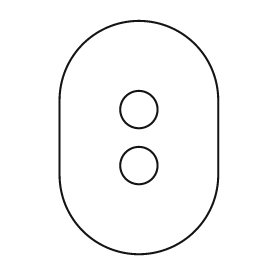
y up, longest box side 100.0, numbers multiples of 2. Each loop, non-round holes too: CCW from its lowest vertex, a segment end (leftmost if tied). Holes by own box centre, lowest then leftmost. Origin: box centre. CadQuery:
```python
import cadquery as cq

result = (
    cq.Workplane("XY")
    .moveTo(-34.0, -16.0)
    .threePointArc((0.0, -50.0), (34.0, -16.0))
    .lineTo(34.0, 16.0)
    .threePointArc((0.0, 50.0), (-34.0, 16.0))
    .close()
    .moveTo(0.0, -12.0)
    .circle(8.0)
    .moveTo(0.0, 12.0)
    .circle(8.0)
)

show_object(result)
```